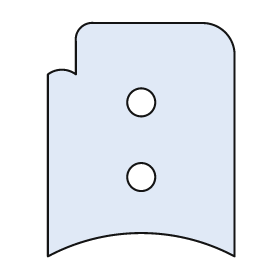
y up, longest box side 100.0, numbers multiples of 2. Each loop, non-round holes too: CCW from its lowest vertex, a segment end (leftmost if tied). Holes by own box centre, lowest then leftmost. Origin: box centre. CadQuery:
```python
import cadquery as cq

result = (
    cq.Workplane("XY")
    .moveTo(-40.0, -50.0)
    .threePointArc((0.0, -40.0), (40.0, -50.0))
    .lineTo(40.0, 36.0)
    .threePointArc((36.0, 46.0), (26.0, 50.0))
    .lineTo(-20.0, 50.0)
    .threePointArc((-26.0, 48.0), (-28.0, 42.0))
    .lineTo(-28.0, 28.0)
    .threePointArc((-34.0, 30.0), (-40.0, 28.0))
    .close()
    .moveTo(0.0, -16.0)
    .circle(6.0)
    .moveTo(0.0, 16.0)
    .circle(6.0)
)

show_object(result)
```